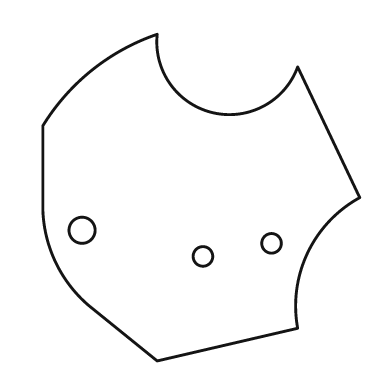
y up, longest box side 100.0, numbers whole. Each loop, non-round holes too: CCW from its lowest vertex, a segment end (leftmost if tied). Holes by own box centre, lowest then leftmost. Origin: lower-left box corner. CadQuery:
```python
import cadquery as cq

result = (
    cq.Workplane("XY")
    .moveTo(35.0, 0.0)
    .lineTo(78.0, 10.0)
    .threePointArc((81.0, 33.0), (97.0, 50.0))
    .lineTo(78.0, 90.0)
    .threePointArc((52.0, 76.0), (35.0, 100.0))
    .threePointArc((15.0, 89.0), (0.0, 72.0))
    .lineTo(0.0, 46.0)
    .threePointArc((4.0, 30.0), (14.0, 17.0))
    .close()
    .moveTo(49.0, 32.0)
    .circle(3.0)
    .moveTo(70.0, 36.0)
    .circle(3.0)
    .moveTo(12.0, 40.0)
    .circle(4.0)
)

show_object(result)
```